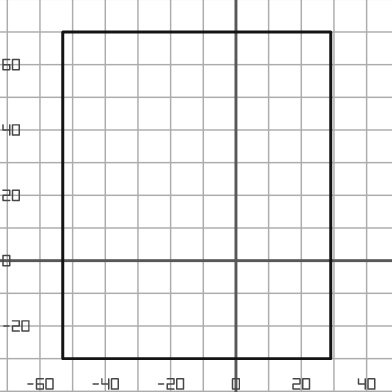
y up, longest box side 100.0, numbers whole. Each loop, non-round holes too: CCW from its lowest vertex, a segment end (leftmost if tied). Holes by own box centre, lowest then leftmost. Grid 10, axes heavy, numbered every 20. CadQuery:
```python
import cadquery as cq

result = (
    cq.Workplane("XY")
    .moveTo(-53.0, -30.0)
    .lineTo(29.0, -30.0)
    .lineTo(29.0, 70.0)
    .lineTo(-53.0, 70.0)
    .close()
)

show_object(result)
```